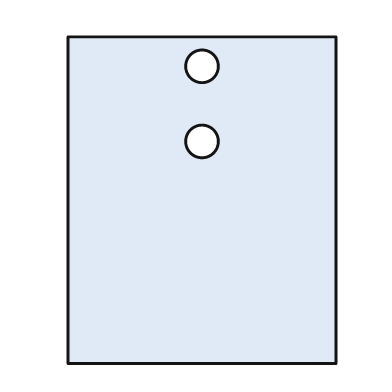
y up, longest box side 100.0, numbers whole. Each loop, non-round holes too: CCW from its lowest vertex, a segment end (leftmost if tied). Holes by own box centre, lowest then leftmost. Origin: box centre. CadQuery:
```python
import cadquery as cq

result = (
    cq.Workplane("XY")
    .moveTo(-41.0, -50.0)
    .lineTo(41.0, -50.0)
    .lineTo(41.0, 50.0)
    .lineTo(-41.0, 50.0)
    .close()
    .moveTo(0.0, 18.0)
    .circle(5.0)
    .moveTo(0.0, 41.0)
    .circle(5.0)
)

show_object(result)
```